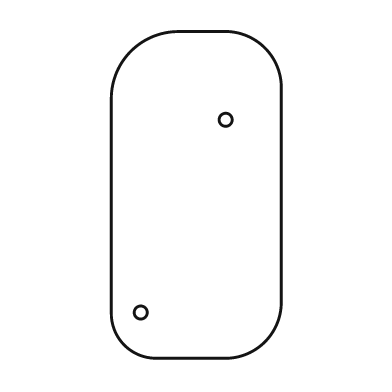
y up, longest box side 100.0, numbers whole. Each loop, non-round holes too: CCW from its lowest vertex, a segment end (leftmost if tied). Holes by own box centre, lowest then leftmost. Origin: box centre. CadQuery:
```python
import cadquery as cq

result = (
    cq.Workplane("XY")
    .moveTo(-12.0, -50.0)
    .lineTo(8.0, -50.0)
    .threePointArc((21.0, -45.0), (26.0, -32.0))
    .lineTo(26.0, 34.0)
    .threePointArc((21.0, 45.0), (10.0, 50.0))
    .lineTo(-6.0, 50.0)
    .threePointArc((-20.0, 44.0), (-26.0, 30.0))
    .lineTo(-26.0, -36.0)
    .threePointArc((-22.0, -46.0), (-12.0, -50.0))
    .close()
    .moveTo(-17.0, -36.0)
    .circle(2.0)
    .moveTo(9.0, 23.0)
    .circle(2.0)
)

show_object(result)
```